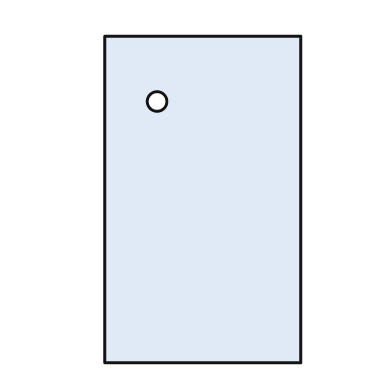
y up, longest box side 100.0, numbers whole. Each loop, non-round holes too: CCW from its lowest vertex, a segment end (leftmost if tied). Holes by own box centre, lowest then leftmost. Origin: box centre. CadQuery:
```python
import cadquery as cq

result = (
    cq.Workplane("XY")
    .moveTo(-30.0, -50.0)
    .lineTo(30.0, -50.0)
    .lineTo(30.0, 50.0)
    .lineTo(-30.0, 50.0)
    .close()
    .moveTo(-14.0, 30.0)
    .circle(3.0)
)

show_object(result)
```